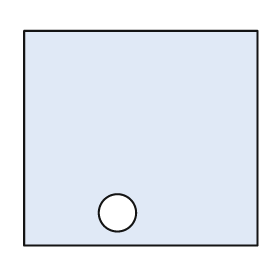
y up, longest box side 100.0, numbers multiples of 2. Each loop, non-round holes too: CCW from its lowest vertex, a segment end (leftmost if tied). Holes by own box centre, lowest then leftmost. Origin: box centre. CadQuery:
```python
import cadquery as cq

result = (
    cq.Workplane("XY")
    .moveTo(-50.0, -46.0)
    .lineTo(50.0, -46.0)
    .lineTo(50.0, 46.0)
    .lineTo(-50.0, 46.0)
    .close()
    .moveTo(-10.0, -32.0)
    .circle(8.0)
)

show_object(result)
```